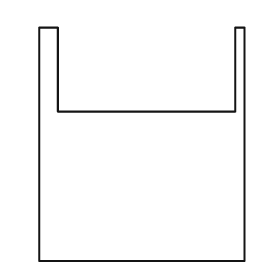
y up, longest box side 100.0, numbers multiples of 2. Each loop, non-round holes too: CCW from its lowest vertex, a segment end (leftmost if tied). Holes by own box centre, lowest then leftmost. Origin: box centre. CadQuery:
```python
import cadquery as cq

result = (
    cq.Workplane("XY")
    .moveTo(-44.0, -50.0)
    .lineTo(44.0, -50.0)
    .lineTo(44.0, 50.0)
    .lineTo(40.0, 50.0)
    .lineTo(40.0, 14.0)
    .lineTo(-36.0, 14.0)
    .lineTo(-36.0, 50.0)
    .lineTo(-44.0, 50.0)
    .close()
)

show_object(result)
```